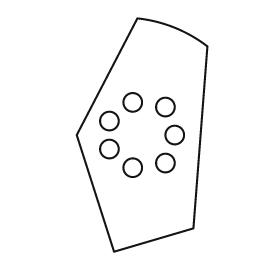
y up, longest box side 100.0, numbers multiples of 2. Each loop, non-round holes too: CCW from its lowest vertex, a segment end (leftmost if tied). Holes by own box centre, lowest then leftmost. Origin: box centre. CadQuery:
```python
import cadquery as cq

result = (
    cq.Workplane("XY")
    .moveTo(-12.0, -50.0)
    .lineTo(22.0, -40.0)
    .lineTo(28.0, 38.0)
    .threePointArc((14.0, 46.0), (-2.0, 50.0))
    .lineTo(-28.0, 0.0)
    .close()
    .moveTo(-4.0, -14.0)
    .circle(4.0)
    .moveTo(10.0, -12.0)
    .circle(4.0)
    .moveTo(-14.0, -6.0)
    .circle(4.0)
    .moveTo(14.0, 0.0)
    .circle(4.0)
    .moveTo(-14.0, 6.0)
    .circle(4.0)
    .moveTo(10.0, 12.0)
    .circle(4.0)
    .moveTo(-4.0, 14.0)
    .circle(4.0)
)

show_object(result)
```